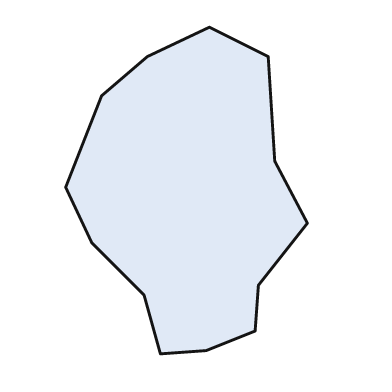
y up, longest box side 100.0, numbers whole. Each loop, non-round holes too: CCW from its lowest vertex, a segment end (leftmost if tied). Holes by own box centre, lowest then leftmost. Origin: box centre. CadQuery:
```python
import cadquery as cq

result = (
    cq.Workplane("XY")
    .moveTo(-8.0, -50.0)
    .lineTo(6.0, -49.0)
    .lineTo(21.0, -43.0)
    .lineTo(22.0, -29.0)
    .lineTo(37.0, -10.0)
    .lineTo(27.0, 9.0)
    .lineTo(25.0, 41.0)
    .lineTo(7.0, 50.0)
    .lineTo(-12.0, 41.0)
    .lineTo(-26.0, 29.0)
    .lineTo(-37.0, 1.0)
    .lineTo(-29.0, -16.0)
    .lineTo(-13.0, -32.0)
    .close()
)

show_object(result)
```